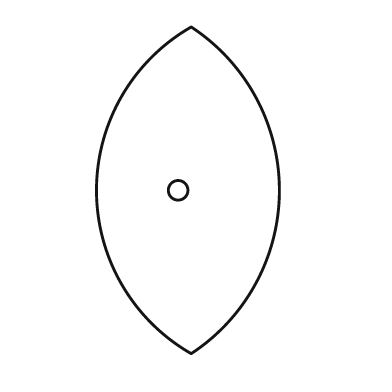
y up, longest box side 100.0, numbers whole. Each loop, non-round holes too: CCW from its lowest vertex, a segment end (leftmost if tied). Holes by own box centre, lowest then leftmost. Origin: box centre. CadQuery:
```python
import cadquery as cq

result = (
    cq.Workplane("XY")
    .moveTo(1.0, -50.0)
    .threePointArc((28.0, 0.0), (1.0, 50.0))
    .threePointArc((-28.0, 0.0), (1.0, -50.0))
    .close()
    .moveTo(-3.0, 0.0)
    .circle(3.0)
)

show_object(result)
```